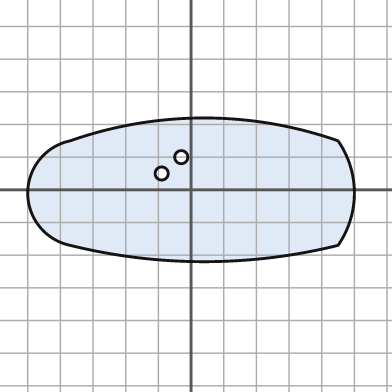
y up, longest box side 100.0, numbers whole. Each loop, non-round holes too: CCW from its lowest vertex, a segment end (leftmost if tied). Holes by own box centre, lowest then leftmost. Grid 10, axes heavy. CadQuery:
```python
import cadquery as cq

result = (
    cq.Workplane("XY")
    .moveTo(-37.0, -17.0)
    .threePointArc((4.0, -22.0), (45.0, -17.0))
    .threePointArc((50.0, -1.0), (45.0, 15.0))
    .threePointArc((4.0, 22.0), (-37.0, 15.0))
    .threePointArc((-50.0, -1.0), (-37.0, -17.0))
    .close()
    .moveTo(-9.0, 5.0)
    .circle(2.0)
    .moveTo(-3.0, 10.0)
    .circle(2.0)
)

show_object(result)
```